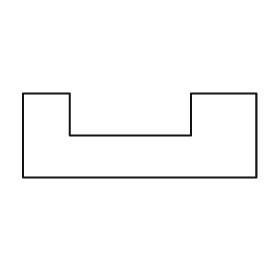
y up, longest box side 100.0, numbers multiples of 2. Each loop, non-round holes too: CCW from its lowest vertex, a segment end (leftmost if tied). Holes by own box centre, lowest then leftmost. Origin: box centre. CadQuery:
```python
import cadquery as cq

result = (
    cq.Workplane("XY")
    .moveTo(-50.0, -18.0)
    .lineTo(50.0, -18.0)
    .lineTo(50.0, 18.0)
    .lineTo(22.0, 18.0)
    .lineTo(22.0, 0.0)
    .lineTo(-30.0, 0.0)
    .lineTo(-30.0, 18.0)
    .lineTo(-50.0, 18.0)
    .close()
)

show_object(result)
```